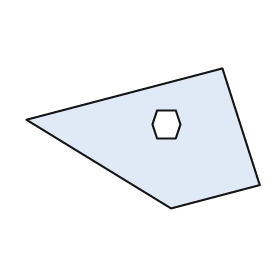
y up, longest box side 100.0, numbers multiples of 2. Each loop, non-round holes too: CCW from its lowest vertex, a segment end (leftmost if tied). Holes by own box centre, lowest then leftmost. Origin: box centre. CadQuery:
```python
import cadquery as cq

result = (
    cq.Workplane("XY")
    .moveTo(12.0, -30.0)
    .lineTo(50.0, -20.0)
    .lineTo(34.0, 30.0)
    .lineTo(-50.0, 8.0)
    .close()
    .moveTo(6.0, 0.0)
    .lineTo(14.0, 0.0)
    .lineTo(16.0, 6.0)
    .lineTo(14.0, 12.0)
    .lineTo(6.0, 12.0)
    .lineTo(4.0, 6.0)
    .close()
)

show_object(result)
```